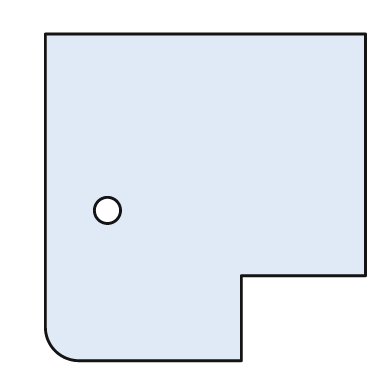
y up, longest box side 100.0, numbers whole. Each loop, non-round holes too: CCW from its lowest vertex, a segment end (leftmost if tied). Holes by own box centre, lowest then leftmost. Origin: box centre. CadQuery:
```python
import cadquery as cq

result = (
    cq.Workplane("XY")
    .moveTo(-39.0, -50.0)
    .lineTo(11.0, -50.0)
    .lineTo(11.0, -24.0)
    .lineTo(49.0, -24.0)
    .lineTo(49.0, 50.0)
    .lineTo(-49.0, 50.0)
    .lineTo(-49.0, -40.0)
    .threePointArc((-46.0, -47.0), (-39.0, -50.0))
    .close()
    .moveTo(-30.0, -4.0)
    .circle(4.0)
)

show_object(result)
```